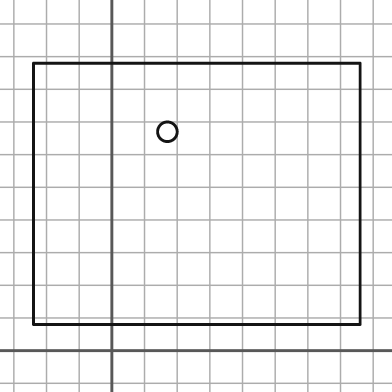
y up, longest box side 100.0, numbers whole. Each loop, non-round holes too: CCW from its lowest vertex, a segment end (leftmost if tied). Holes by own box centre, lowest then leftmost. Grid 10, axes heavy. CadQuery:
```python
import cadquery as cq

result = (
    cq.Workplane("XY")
    .moveTo(-24.0, 8.0)
    .lineTo(76.0, 8.0)
    .lineTo(76.0, 88.0)
    .lineTo(-24.0, 88.0)
    .close()
    .moveTo(17.0, 67.0)
    .circle(3.0)
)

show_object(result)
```